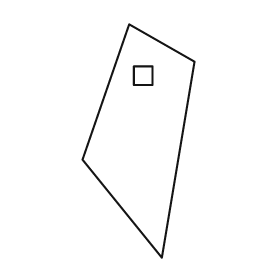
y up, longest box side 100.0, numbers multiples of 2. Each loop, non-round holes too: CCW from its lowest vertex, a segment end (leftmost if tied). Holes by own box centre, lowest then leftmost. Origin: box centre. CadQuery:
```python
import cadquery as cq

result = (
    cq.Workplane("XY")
    .moveTo(10.0, -50.0)
    .lineTo(24.0, 34.0)
    .lineTo(-4.0, 50.0)
    .lineTo(-24.0, -8.0)
    .close()
    .moveTo(-2.0, 24.0)
    .lineTo(6.0, 24.0)
    .lineTo(6.0, 32.0)
    .lineTo(-2.0, 32.0)
    .close()
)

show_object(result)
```